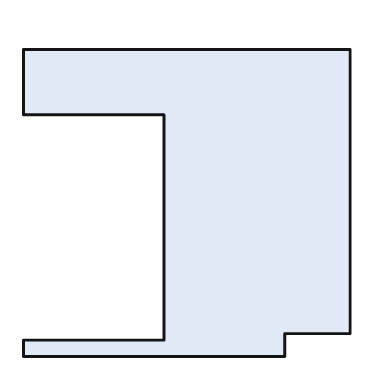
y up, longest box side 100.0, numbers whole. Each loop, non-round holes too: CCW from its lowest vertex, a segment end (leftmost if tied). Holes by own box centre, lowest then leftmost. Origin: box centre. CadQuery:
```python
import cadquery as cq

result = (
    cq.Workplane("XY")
    .moveTo(-50.0, -47.0)
    .lineTo(30.0, -47.0)
    .lineTo(30.0, -40.0)
    .lineTo(50.0, -40.0)
    .lineTo(50.0, 47.0)
    .lineTo(-50.0, 47.0)
    .lineTo(-50.0, 27.0)
    .lineTo(-7.0, 27.0)
    .lineTo(-7.0, -42.0)
    .lineTo(-50.0, -42.0)
    .close()
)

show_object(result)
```